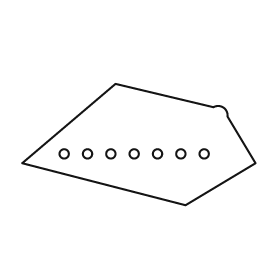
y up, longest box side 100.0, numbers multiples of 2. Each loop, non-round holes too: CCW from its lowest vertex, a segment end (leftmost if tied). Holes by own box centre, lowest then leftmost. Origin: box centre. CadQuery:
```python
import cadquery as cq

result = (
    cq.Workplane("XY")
    .moveTo(20.0, -26.0)
    .lineTo(50.0, -8.0)
    .lineTo(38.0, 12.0)
    .threePointArc((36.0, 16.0), (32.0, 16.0))
    .lineTo(-10.0, 26.0)
    .lineTo(-50.0, -8.0)
    .close()
    .moveTo(-32.0, -4.0)
    .circle(2.0)
    .moveTo(-22.0, -4.0)
    .circle(2.0)
    .moveTo(-12.0, -4.0)
    .circle(2.0)
    .moveTo(-2.0, -4.0)
    .circle(2.0)
    .moveTo(8.0, -4.0)
    .circle(2.0)
    .moveTo(18.0, -4.0)
    .circle(2.0)
    .moveTo(28.0, -4.0)
    .circle(2.0)
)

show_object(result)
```